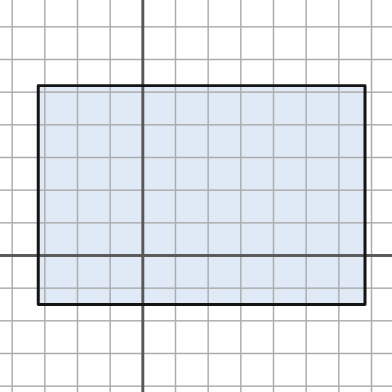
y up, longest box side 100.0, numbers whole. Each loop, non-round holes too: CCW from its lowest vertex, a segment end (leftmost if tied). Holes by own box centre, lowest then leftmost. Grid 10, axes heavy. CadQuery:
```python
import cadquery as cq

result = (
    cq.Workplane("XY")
    .moveTo(-32.0, -15.0)
    .lineTo(68.0, -15.0)
    .lineTo(68.0, 52.0)
    .lineTo(-32.0, 52.0)
    .close()
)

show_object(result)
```